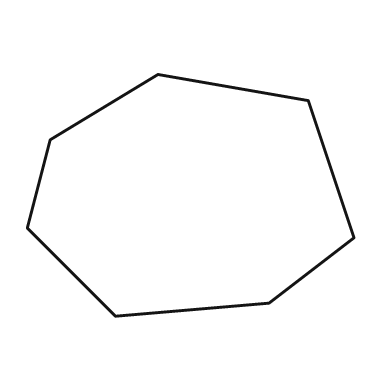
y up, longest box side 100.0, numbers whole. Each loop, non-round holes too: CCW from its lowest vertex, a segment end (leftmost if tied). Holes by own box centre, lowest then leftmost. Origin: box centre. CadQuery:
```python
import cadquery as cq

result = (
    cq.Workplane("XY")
    .moveTo(-23.0, -37.0)
    .lineTo(24.0, -33.0)
    .lineTo(50.0, -13.0)
    .lineTo(36.0, 29.0)
    .lineTo(-10.0, 37.0)
    .lineTo(-43.0, 17.0)
    .lineTo(-50.0, -10.0)
    .close()
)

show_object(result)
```